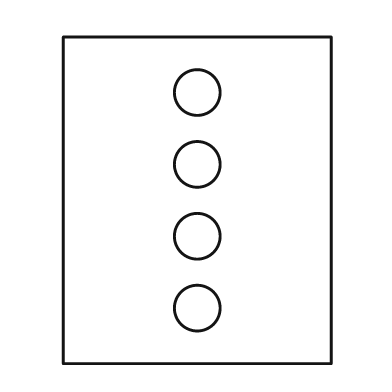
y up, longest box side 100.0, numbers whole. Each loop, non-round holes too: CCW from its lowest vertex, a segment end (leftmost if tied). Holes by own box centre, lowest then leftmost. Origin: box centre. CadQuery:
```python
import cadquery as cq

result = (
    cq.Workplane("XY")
    .moveTo(-41.0, -50.0)
    .lineTo(41.0, -50.0)
    .lineTo(41.0, 50.0)
    .lineTo(-41.0, 50.0)
    .close()
    .moveTo(0.0, -33.0)
    .circle(7.0)
    .moveTo(0.0, -11.0)
    .circle(7.0)
    .moveTo(0.0, 11.0)
    .circle(7.0)
    .moveTo(0.0, 33.0)
    .circle(7.0)
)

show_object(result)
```